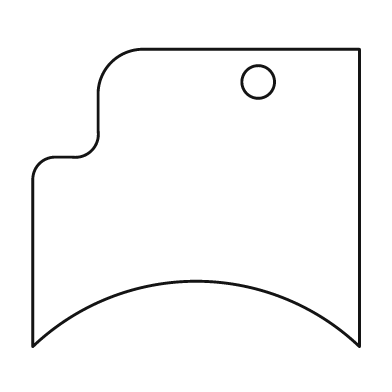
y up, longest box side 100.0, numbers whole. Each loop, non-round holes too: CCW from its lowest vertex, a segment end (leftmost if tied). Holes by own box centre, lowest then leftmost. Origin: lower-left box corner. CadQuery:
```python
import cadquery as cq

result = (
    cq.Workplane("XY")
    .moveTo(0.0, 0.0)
    .threePointArc((50.0, 20.0), (100.0, 0.0))
    .lineTo(100.0, 91.0)
    .lineTo(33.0, 91.0)
    .threePointArc((24.0, 87.0), (20.0, 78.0))
    .lineTo(20.0, 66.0)
    .threePointArc((18.0, 60.0), (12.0, 58.0))
    .lineTo(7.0, 58.0)
    .threePointArc((2.0, 56.0), (0.0, 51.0))
    .close()
    .moveTo(69.0, 81.0)
    .circle(5.0)
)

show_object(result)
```